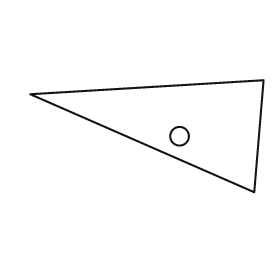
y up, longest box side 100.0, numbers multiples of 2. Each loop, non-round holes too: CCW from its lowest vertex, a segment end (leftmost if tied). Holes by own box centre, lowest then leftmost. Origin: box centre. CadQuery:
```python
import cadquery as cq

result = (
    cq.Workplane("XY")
    .moveTo(46.0, -24.0)
    .lineTo(50.0, 24.0)
    .lineTo(-50.0, 18.0)
    .close()
    .moveTo(14.0, 0.0)
    .circle(4.0)
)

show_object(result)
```